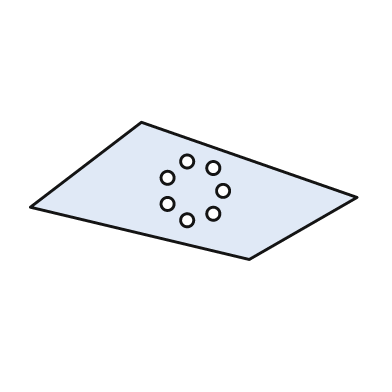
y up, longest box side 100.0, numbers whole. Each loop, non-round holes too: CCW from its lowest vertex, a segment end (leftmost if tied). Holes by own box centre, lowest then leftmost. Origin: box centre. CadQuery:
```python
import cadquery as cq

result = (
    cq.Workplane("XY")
    .moveTo(17.0, -21.0)
    .lineTo(50.0, -2.0)
    .lineTo(-16.0, 21.0)
    .lineTo(-50.0, -5.0)
    .close()
    .moveTo(-2.0, -9.0)
    .circle(2.0)
    .moveTo(6.0, -7.0)
    .circle(2.0)
    .moveTo(-8.0, -4.0)
    .circle(2.0)
    .moveTo(9.0, 0.0)
    .circle(2.0)
    .moveTo(-8.0, 4.0)
    .circle(2.0)
    .moveTo(6.0, 7.0)
    .circle(2.0)
    .moveTo(-2.0, 9.0)
    .circle(2.0)
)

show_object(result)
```